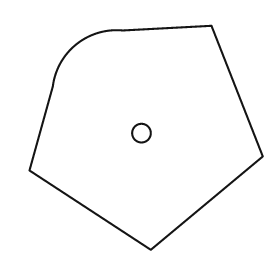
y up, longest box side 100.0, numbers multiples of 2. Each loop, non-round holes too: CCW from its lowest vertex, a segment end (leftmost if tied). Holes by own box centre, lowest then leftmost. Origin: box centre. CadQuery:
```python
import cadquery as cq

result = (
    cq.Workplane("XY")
    .moveTo(2.0, -48.0)
    .lineTo(50.0, -8.0)
    .lineTo(28.0, 48.0)
    .lineTo(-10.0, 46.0)
    .threePointArc((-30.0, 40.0), (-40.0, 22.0))
    .lineTo(-50.0, -14.0)
    .close()
    .moveTo(-2.0, 2.0)
    .circle(4.0)
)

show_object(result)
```